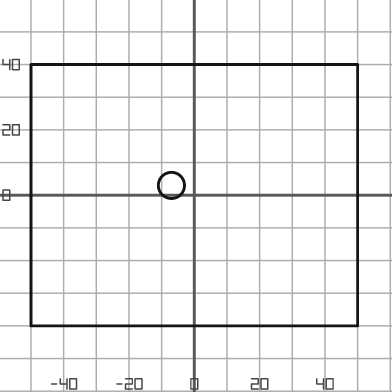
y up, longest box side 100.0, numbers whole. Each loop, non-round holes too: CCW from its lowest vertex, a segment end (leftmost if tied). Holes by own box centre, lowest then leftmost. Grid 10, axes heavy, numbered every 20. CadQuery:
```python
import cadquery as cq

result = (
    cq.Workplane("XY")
    .moveTo(-50.0, -40.0)
    .lineTo(50.0, -40.0)
    .lineTo(50.0, 40.0)
    .lineTo(-50.0, 40.0)
    .close()
    .moveTo(-7.0, 3.0)
    .circle(4.0)
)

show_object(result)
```